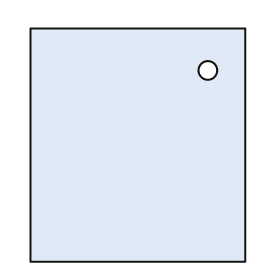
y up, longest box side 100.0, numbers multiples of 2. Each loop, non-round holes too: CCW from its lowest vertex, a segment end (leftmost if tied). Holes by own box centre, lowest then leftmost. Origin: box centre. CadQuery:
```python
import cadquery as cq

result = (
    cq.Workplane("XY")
    .moveTo(-46.0, -50.0)
    .lineTo(46.0, -50.0)
    .lineTo(46.0, 50.0)
    .lineTo(-46.0, 50.0)
    .close()
    .moveTo(30.0, 32.0)
    .circle(4.0)
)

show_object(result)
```